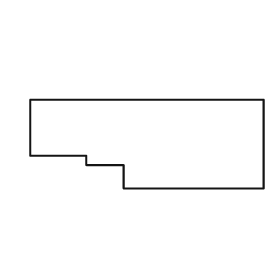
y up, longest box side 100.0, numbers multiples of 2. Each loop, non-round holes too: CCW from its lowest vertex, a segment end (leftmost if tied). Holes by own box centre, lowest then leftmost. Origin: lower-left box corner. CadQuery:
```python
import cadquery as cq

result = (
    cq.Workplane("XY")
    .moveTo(40.0, 0.0)
    .lineTo(100.0, 0.0)
    .lineTo(100.0, 38.0)
    .lineTo(0.0, 38.0)
    .lineTo(0.0, 14.0)
    .lineTo(24.0, 14.0)
    .lineTo(24.0, 10.0)
    .lineTo(40.0, 10.0)
    .close()
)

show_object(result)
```